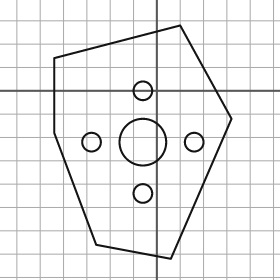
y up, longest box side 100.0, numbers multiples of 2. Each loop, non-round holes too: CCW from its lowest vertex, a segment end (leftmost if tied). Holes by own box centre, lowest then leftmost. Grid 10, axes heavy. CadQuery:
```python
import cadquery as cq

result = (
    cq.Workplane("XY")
    .moveTo(6.0, -72.0)
    .lineTo(32.0, -12.0)
    .lineTo(10.0, 28.0)
    .lineTo(-44.0, 14.0)
    .lineTo(-44.0, -18.0)
    .lineTo(-26.0, -66.0)
    .close()
    .moveTo(-6.0, -44.0)
    .circle(4.0)
    .moveTo(-28.0, -22.0)
    .circle(4.0)
    .moveTo(-6.0, -22.0)
    .circle(10.0)
    .moveTo(16.0, -22.0)
    .circle(4.0)
    .moveTo(-6.0, 0.0)
    .circle(4.0)
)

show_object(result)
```